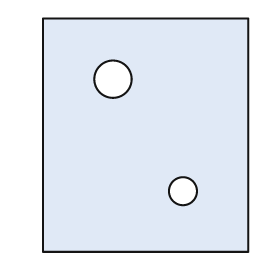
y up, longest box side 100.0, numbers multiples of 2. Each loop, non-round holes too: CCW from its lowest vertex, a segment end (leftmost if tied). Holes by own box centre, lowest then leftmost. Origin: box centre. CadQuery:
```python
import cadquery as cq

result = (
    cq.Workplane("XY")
    .moveTo(-44.0, -50.0)
    .lineTo(44.0, -50.0)
    .lineTo(44.0, 50.0)
    .lineTo(-44.0, 50.0)
    .close()
    .moveTo(16.0, -24.0)
    .circle(6.0)
    .moveTo(-14.0, 24.0)
    .circle(8.0)
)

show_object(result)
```